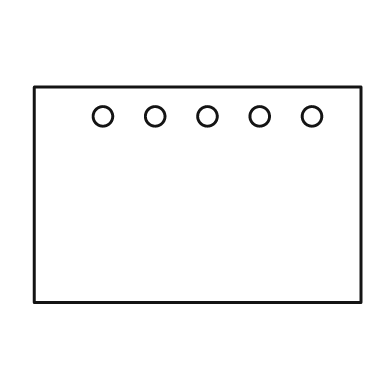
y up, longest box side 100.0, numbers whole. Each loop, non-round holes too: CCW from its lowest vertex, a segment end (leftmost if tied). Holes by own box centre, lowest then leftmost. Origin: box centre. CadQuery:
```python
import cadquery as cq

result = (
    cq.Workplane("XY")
    .moveTo(-50.0, -33.0)
    .lineTo(50.0, -33.0)
    .lineTo(50.0, 33.0)
    .lineTo(-50.0, 33.0)
    .close()
    .moveTo(-29.0, 24.0)
    .circle(3.0)
    .moveTo(-13.0, 24.0)
    .circle(3.0)
    .moveTo(3.0, 24.0)
    .circle(3.0)
    .moveTo(19.0, 24.0)
    .circle(3.0)
    .moveTo(35.0, 24.0)
    .circle(3.0)
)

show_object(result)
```